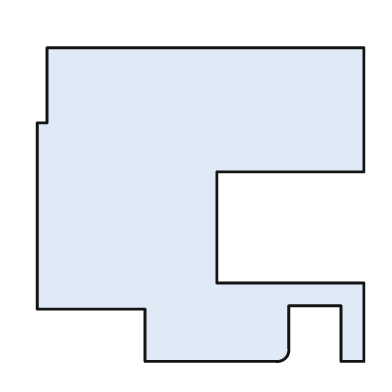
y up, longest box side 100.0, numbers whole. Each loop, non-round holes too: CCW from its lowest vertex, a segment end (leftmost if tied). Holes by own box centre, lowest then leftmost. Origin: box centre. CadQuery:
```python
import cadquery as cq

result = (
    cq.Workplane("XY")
    .moveTo(-17.0, -48.0)
    .lineTo(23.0, -48.0)
    .threePointArc((26.0, -47.0), (27.0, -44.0))
    .lineTo(27.0, -31.0)
    .lineTo(43.0, -31.0)
    .lineTo(43.0, -48.0)
    .lineTo(50.0, -48.0)
    .lineTo(50.0, -24.0)
    .lineTo(5.0, -24.0)
    .lineTo(5.0, 10.0)
    .lineTo(50.0, 10.0)
    .lineTo(50.0, 48.0)
    .lineTo(-47.0, 48.0)
    .lineTo(-47.0, 25.0)
    .lineTo(-50.0, 25.0)
    .lineTo(-50.0, -32.0)
    .lineTo(-17.0, -32.0)
    .close()
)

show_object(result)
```